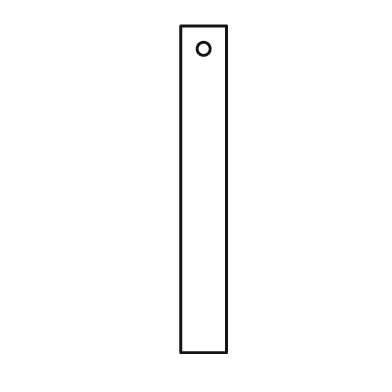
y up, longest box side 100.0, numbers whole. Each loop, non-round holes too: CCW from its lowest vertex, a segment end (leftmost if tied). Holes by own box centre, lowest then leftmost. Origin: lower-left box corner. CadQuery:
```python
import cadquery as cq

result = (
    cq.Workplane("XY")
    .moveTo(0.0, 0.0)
    .lineTo(14.0, 0.0)
    .lineTo(14.0, 100.0)
    .lineTo(0.0, 100.0)
    .close()
    .moveTo(7.0, 93.0)
    .circle(2.0)
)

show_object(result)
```